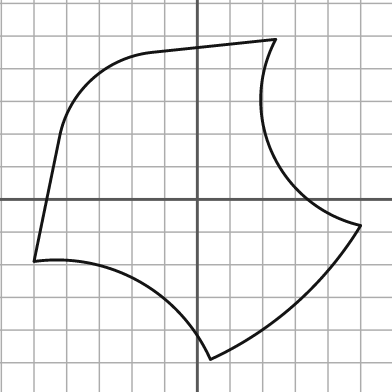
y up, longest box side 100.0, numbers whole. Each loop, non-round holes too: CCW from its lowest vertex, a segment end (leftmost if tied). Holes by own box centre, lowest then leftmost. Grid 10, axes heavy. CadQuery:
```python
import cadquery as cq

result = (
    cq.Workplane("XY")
    .moveTo(4.0, -49.0)
    .threePointArc((30.0, -32.0), (50.0, -8.0))
    .threePointArc((23.0, 14.0), (24.0, 49.0))
    .lineTo(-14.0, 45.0)
    .threePointArc((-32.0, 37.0), (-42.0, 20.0))
    .lineTo(-50.0, -19.0)
    .threePointArc((-18.0, -25.0), (4.0, -49.0))
    .close()
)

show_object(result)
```